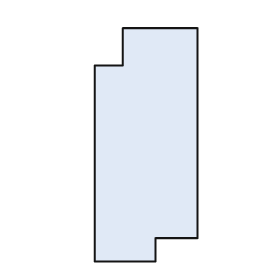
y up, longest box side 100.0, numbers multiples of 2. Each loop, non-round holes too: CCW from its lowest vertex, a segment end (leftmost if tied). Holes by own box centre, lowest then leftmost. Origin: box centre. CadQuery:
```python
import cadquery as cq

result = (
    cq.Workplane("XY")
    .moveTo(-22.0, -50.0)
    .lineTo(4.0, -50.0)
    .lineTo(4.0, -40.0)
    .lineTo(22.0, -40.0)
    .lineTo(22.0, 50.0)
    .lineTo(-10.0, 50.0)
    .lineTo(-10.0, 34.0)
    .lineTo(-22.0, 34.0)
    .close()
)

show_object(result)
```